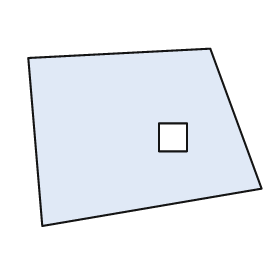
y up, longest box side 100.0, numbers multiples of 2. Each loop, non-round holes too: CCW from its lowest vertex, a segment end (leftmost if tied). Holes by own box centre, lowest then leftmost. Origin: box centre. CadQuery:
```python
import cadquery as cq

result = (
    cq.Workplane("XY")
    .moveTo(-44.0, -38.0)
    .lineTo(50.0, -22.0)
    .lineTo(28.0, 38.0)
    .lineTo(-50.0, 34.0)
    .close()
    .moveTo(6.0, -6.0)
    .lineTo(18.0, -6.0)
    .lineTo(18.0, 6.0)
    .lineTo(6.0, 6.0)
    .close()
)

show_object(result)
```